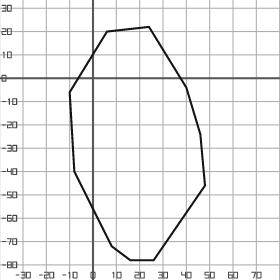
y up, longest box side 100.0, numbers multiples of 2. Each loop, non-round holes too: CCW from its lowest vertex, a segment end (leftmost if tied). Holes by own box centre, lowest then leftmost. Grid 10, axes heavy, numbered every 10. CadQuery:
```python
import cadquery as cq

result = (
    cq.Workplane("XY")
    .moveTo(16.0, -78.0)
    .lineTo(26.0, -78.0)
    .lineTo(48.0, -46.0)
    .lineTo(46.0, -24.0)
    .lineTo(40.0, -4.0)
    .lineTo(24.0, 22.0)
    .lineTo(6.0, 20.0)
    .lineTo(-10.0, -6.0)
    .lineTo(-8.0, -40.0)
    .lineTo(8.0, -72.0)
    .close()
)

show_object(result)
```